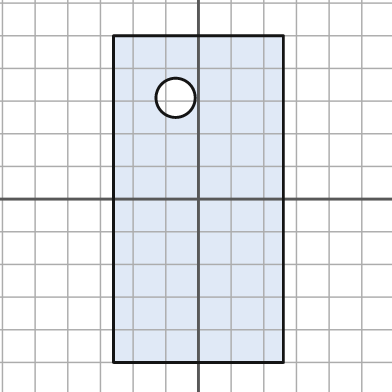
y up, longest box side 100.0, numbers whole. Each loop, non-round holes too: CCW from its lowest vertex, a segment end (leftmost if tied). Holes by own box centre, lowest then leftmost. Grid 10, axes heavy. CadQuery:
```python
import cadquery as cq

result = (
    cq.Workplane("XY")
    .moveTo(-26.0, -50.0)
    .lineTo(26.0, -50.0)
    .lineTo(26.0, 50.0)
    .lineTo(-26.0, 50.0)
    .close()
    .moveTo(-7.0, 31.0)
    .circle(6.0)
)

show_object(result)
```